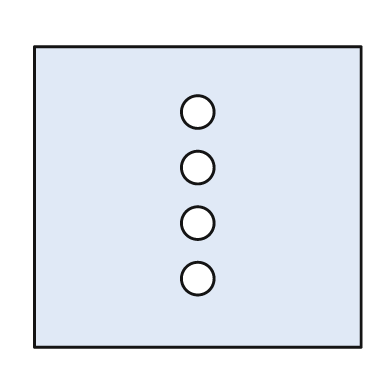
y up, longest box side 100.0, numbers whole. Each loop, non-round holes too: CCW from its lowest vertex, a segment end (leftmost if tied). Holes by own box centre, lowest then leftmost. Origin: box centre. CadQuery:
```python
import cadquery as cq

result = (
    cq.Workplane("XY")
    .moveTo(-50.0, -46.0)
    .lineTo(50.0, -46.0)
    .lineTo(50.0, 46.0)
    .lineTo(-50.0, 46.0)
    .close()
    .moveTo(0.0, -25.0)
    .circle(5.0)
    .moveTo(0.0, -8.0)
    .circle(5.0)
    .moveTo(0.0, 9.0)
    .circle(5.0)
    .moveTo(0.0, 26.0)
    .circle(5.0)
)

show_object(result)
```